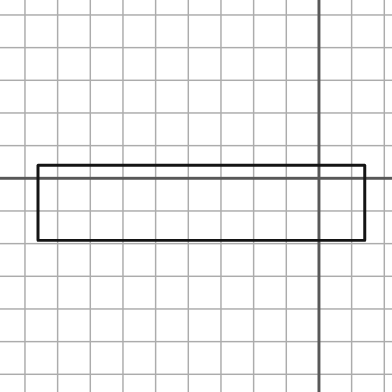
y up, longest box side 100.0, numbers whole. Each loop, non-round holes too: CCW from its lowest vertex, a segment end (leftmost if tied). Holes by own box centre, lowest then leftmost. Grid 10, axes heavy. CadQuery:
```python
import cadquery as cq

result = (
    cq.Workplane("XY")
    .moveTo(-86.0, -19.0)
    .lineTo(14.0, -19.0)
    .lineTo(14.0, 4.0)
    .lineTo(-86.0, 4.0)
    .close()
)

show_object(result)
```